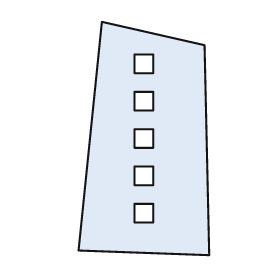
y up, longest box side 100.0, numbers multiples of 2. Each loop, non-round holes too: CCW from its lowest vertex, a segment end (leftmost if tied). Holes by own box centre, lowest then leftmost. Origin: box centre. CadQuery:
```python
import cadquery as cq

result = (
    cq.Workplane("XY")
    .moveTo(28.0, -50.0)
    .lineTo(26.0, 40.0)
    .lineTo(-18.0, 50.0)
    .lineTo(-28.0, -48.0)
    .close()
    .moveTo(-4.0, -36.0)
    .lineTo(4.0, -36.0)
    .lineTo(4.0, -28.0)
    .lineTo(-4.0, -28.0)
    .close()
    .moveTo(-4.0, -20.0)
    .lineTo(4.0, -20.0)
    .lineTo(4.0, -12.0)
    .lineTo(-4.0, -12.0)
    .close()
    .moveTo(-4.0, -4.0)
    .lineTo(4.0, -4.0)
    .lineTo(4.0, 4.0)
    .lineTo(-4.0, 4.0)
    .close()
    .moveTo(-4.0, 12.0)
    .lineTo(4.0, 12.0)
    .lineTo(4.0, 20.0)
    .lineTo(-4.0, 20.0)
    .close()
    .moveTo(-4.0, 28.0)
    .lineTo(4.0, 28.0)
    .lineTo(4.0, 36.0)
    .lineTo(-4.0, 36.0)
    .close()
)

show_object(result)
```